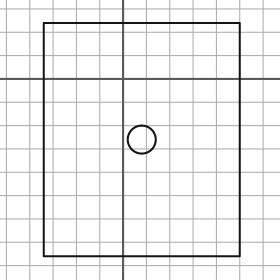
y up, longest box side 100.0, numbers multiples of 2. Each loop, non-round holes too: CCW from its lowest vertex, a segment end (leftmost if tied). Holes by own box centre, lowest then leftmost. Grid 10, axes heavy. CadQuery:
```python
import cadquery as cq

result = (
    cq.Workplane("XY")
    .moveTo(-34.0, -76.0)
    .lineTo(50.0, -76.0)
    .lineTo(50.0, 24.0)
    .lineTo(-34.0, 24.0)
    .close()
    .moveTo(8.0, -26.0)
    .circle(6.0)
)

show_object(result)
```